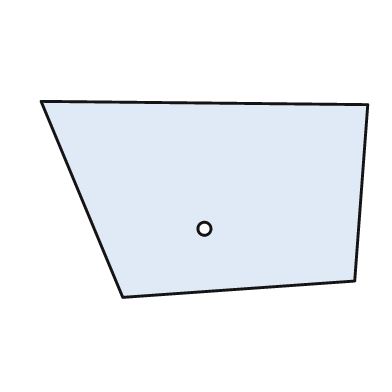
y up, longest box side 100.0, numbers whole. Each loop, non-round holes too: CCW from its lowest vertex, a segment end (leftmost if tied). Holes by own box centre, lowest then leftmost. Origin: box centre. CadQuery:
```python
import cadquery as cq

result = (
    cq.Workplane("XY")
    .moveTo(-25.0, -30.0)
    .lineTo(46.0, -25.0)
    .lineTo(50.0, 29.0)
    .lineTo(-50.0, 30.0)
    .close()
    .moveTo(0.0, -9.0)
    .circle(2.0)
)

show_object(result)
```